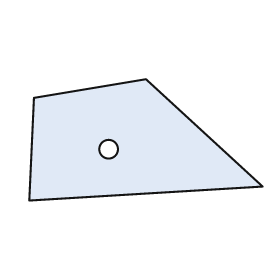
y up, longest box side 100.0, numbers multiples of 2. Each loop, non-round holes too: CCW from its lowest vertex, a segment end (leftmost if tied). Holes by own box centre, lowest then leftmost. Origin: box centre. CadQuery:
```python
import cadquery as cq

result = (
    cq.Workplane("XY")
    .moveTo(-50.0, -26.0)
    .lineTo(50.0, -20.0)
    .lineTo(0.0, 26.0)
    .lineTo(-48.0, 18.0)
    .close()
    .moveTo(-16.0, -4.0)
    .circle(4.0)
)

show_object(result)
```